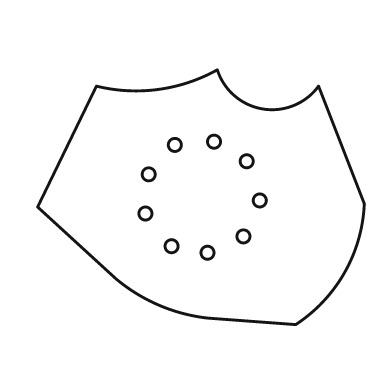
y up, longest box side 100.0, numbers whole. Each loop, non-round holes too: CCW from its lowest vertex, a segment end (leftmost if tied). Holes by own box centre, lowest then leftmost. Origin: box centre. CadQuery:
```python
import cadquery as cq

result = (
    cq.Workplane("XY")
    .moveTo(29.0, -39.0)
    .threePointArc((44.0, -23.0), (50.0, -2.0))
    .lineTo(36.0, 34.0)
    .threePointArc((19.0, 27.0), (5.0, 39.0))
    .threePointArc((-13.0, 33.0), (-32.0, 34.0))
    .lineTo(-50.0, -3.0)
    .lineTo(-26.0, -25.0)
    .threePointArc((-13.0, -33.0), (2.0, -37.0))
    .close()
    .moveTo(2.0, -17.0)
    .circle(2.0)
    .moveTo(-9.0, -15.0)
    .circle(2.0)
    .moveTo(13.0, -12.0)
    .circle(2.0)
    .moveTo(-17.0, -5.0)
    .circle(2.0)
    .moveTo(18.0, -1.0)
    .circle(2.0)
    .moveTo(-16.0, 7.0)
    .circle(2.0)
    .moveTo(14.0, 11.0)
    .circle(2.0)
    .moveTo(-8.0, 16.0)
    .circle(2.0)
    .moveTo(4.0, 17.0)
    .circle(2.0)
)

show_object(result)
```